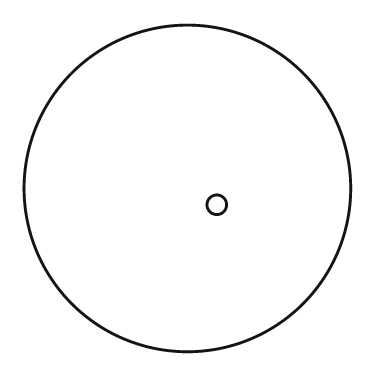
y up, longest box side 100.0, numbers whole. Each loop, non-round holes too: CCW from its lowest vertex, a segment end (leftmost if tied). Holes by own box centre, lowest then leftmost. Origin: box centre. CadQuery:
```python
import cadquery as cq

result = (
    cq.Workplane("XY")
    .moveTo(0.0, 0.0)
    .circle(50.0)
    .moveTo(9.0, -5.0)
    .circle(3.0)
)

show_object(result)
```